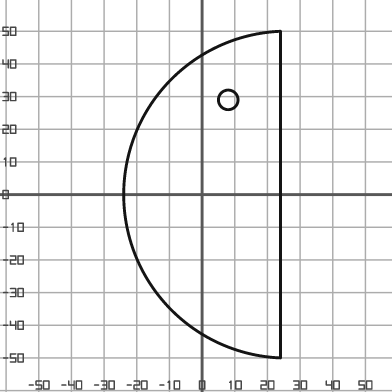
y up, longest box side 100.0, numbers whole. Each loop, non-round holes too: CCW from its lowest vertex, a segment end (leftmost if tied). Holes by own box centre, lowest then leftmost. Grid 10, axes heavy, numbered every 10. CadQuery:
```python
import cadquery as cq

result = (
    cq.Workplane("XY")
    .moveTo(24.0, -50.0)
    .lineTo(24.0, 50.0)
    .threePointArc((-24.0, 0.0), (24.0, -50.0))
    .close()
    .moveTo(8.0, 29.0)
    .circle(3.0)
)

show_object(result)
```